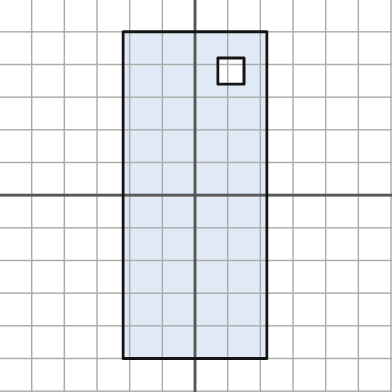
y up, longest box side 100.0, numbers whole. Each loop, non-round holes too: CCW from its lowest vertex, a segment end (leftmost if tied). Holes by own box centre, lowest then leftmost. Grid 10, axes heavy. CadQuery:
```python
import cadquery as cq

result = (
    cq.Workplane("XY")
    .moveTo(-22.0, -50.0)
    .lineTo(22.0, -50.0)
    .lineTo(22.0, 50.0)
    .lineTo(-22.0, 50.0)
    .close()
    .moveTo(7.0, 34.0)
    .lineTo(15.0, 34.0)
    .lineTo(15.0, 42.0)
    .lineTo(7.0, 42.0)
    .close()
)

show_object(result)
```